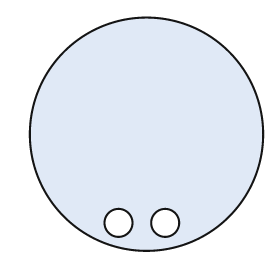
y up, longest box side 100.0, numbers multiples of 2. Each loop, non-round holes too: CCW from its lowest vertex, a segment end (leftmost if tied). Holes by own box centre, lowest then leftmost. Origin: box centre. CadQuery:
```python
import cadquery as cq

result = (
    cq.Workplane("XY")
    .moveTo(0.0, 0.0)
    .circle(50.0)
    .moveTo(-12.0, -38.0)
    .circle(6.0)
    .moveTo(8.0, -38.0)
    .circle(6.0)
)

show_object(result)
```